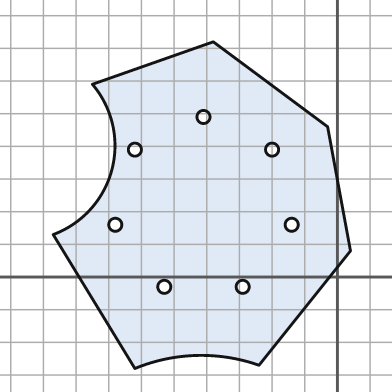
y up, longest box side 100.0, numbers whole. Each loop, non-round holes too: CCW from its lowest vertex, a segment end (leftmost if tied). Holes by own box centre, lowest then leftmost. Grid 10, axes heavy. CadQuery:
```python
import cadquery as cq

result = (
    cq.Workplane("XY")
    .moveTo(-62.0, -28.0)
    .threePointArc((-43.0, -24.0), (-24.0, -27.0))
    .lineTo(4.0, 8.0)
    .lineTo(-3.0, 46.0)
    .lineTo(-38.0, 72.0)
    .lineTo(-75.0, 59.0)
    .threePointArc((-69.0, 33.0), (-87.0, 13.0))
    .close()
    .moveTo(-53.0, -3.0)
    .circle(2.0)
    .moveTo(-29.0, -3.0)
    .circle(2.0)
    .moveTo(-68.0, 16.0)
    .circle(2.0)
    .moveTo(-14.0, 16.0)
    .circle(2.0)
    .moveTo(-62.0, 39.0)
    .circle(2.0)
    .moveTo(-20.0, 39.0)
    .circle(2.0)
    .moveTo(-41.0, 49.0)
    .circle(2.0)
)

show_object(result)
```